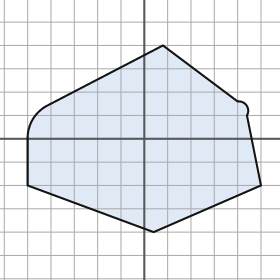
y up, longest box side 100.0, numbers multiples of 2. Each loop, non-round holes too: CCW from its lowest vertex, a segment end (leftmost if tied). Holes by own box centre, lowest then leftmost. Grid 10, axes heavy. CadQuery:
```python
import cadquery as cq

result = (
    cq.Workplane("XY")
    .moveTo(4.0, -40.0)
    .lineTo(50.0, -20.0)
    .lineTo(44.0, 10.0)
    .threePointArc((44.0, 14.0), (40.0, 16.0))
    .lineTo(8.0, 40.0)
    .lineTo(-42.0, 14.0)
    .threePointArc((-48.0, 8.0), (-50.0, 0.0))
    .lineTo(-50.0, -20.0)
    .close()
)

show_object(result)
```